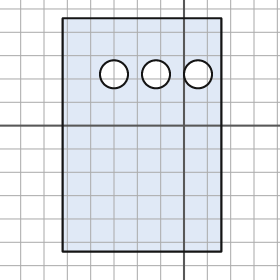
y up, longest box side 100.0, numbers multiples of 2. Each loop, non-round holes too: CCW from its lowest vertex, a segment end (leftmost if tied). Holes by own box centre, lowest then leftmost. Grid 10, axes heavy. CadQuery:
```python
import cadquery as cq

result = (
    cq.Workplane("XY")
    .moveTo(-52.0, -54.0)
    .lineTo(16.0, -54.0)
    .lineTo(16.0, 46.0)
    .lineTo(-52.0, 46.0)
    .close()
    .moveTo(-30.0, 22.0)
    .circle(6.0)
    .moveTo(-12.0, 22.0)
    .circle(6.0)
    .moveTo(6.0, 22.0)
    .circle(6.0)
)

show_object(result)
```